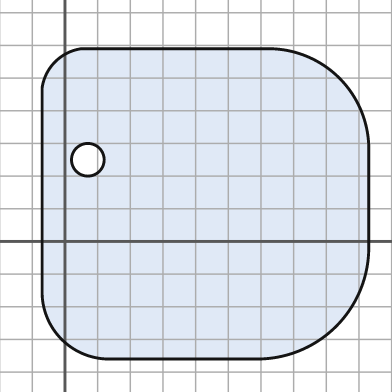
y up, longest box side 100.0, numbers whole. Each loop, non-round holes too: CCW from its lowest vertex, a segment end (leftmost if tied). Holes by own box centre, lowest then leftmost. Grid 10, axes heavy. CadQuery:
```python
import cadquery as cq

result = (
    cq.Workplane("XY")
    .moveTo(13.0, -36.0)
    .lineTo(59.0, -36.0)
    .threePointArc((83.0, -26.0), (93.0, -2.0))
    .lineTo(93.0, 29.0)
    .threePointArc((84.0, 50.0), (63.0, 59.0))
    .lineTo(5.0, 59.0)
    .threePointArc((-3.0, 55.0), (-7.0, 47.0))
    .lineTo(-7.0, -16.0)
    .threePointArc((-1.0, -30.0), (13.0, -36.0))
    .close()
    .moveTo(7.0, 25.0)
    .circle(5.0)
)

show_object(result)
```